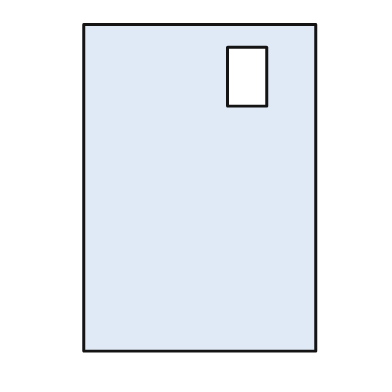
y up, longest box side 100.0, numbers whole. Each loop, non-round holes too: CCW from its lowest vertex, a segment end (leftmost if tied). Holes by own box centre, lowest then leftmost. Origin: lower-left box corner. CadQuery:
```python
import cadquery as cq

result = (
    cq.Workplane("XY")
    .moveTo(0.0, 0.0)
    .lineTo(71.0, 0.0)
    .lineTo(71.0, 100.0)
    .lineTo(0.0, 100.0)
    .close()
    .moveTo(44.0, 75.0)
    .lineTo(56.0, 75.0)
    .lineTo(56.0, 93.0)
    .lineTo(44.0, 93.0)
    .close()
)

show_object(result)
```